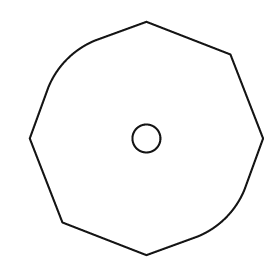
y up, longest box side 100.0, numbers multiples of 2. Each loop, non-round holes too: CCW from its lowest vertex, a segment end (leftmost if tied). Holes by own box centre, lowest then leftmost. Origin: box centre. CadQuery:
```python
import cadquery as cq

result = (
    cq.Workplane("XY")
    .moveTo(0.0, -50.0)
    .lineTo(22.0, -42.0)
    .threePointArc((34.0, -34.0), (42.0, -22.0))
    .lineTo(50.0, 0.0)
    .lineTo(36.0, 36.0)
    .lineTo(0.0, 50.0)
    .lineTo(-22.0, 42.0)
    .threePointArc((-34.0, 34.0), (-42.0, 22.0))
    .lineTo(-50.0, 0.0)
    .lineTo(-36.0, -36.0)
    .close()
    .moveTo(0.0, 0.0)
    .circle(6.0)
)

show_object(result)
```